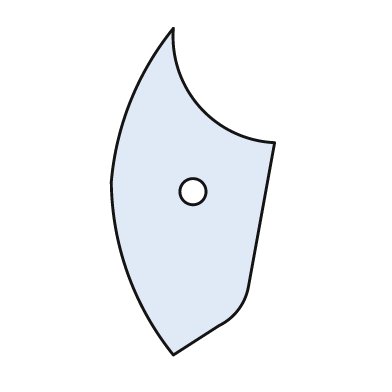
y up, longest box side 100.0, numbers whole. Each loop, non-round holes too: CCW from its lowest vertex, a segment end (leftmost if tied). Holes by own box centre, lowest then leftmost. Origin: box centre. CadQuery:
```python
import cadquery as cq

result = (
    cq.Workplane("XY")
    .moveTo(-6.0, -50.0)
    .lineTo(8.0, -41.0)
    .threePointArc((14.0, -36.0), (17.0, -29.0))
    .lineTo(25.0, 15.0)
    .threePointArc((2.0, 26.0), (-6.0, 50.0))
    .threePointArc((-19.0, 28.0), (-25.0, 3.0))
    .threePointArc((-20.0, -25.0), (-6.0, -50.0))
    .close()
    .moveTo(0.0, 0.0)
    .circle(4.0)
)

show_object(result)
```